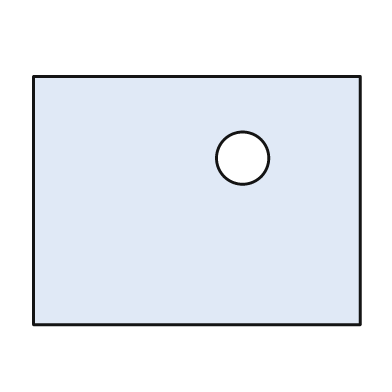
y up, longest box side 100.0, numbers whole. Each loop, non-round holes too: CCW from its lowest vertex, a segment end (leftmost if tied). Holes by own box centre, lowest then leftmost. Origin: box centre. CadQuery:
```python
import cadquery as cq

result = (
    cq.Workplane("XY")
    .moveTo(-50.0, -38.0)
    .lineTo(50.0, -38.0)
    .lineTo(50.0, 38.0)
    .lineTo(-50.0, 38.0)
    .close()
    .moveTo(14.0, 13.0)
    .circle(8.0)
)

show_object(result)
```